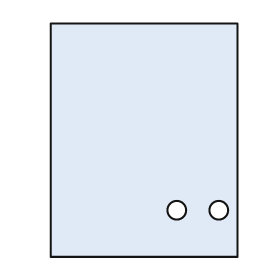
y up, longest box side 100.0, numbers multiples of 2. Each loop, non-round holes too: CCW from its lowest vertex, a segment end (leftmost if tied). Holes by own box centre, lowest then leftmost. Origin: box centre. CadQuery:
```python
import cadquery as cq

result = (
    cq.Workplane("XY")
    .moveTo(-40.0, -50.0)
    .lineTo(40.0, -50.0)
    .lineTo(40.0, 50.0)
    .lineTo(-40.0, 50.0)
    .close()
    .moveTo(14.0, -30.0)
    .circle(4.0)
    .moveTo(32.0, -30.0)
    .circle(4.0)
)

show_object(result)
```